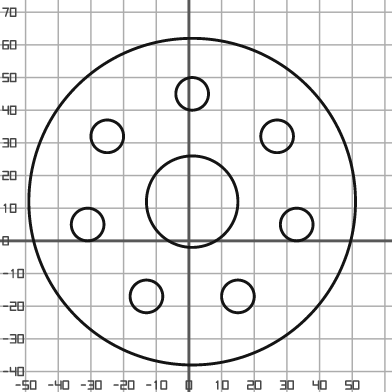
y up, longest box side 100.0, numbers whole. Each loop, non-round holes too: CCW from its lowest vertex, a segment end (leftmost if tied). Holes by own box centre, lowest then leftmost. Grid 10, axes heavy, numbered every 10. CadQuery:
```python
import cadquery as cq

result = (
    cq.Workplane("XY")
    .moveTo(1.0, 12.0)
    .circle(50.0)
    .moveTo(-13.0, -17.0)
    .circle(5.0)
    .moveTo(15.0, -17.0)
    .circle(5.0)
    .moveTo(-31.0, 5.0)
    .circle(5.0)
    .moveTo(33.0, 5.0)
    .circle(5.0)
    .moveTo(1.0, 12.0)
    .circle(14.0)
    .moveTo(-25.0, 32.0)
    .circle(5.0)
    .moveTo(27.0, 32.0)
    .circle(5.0)
    .moveTo(1.0, 45.0)
    .circle(5.0)
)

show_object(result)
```